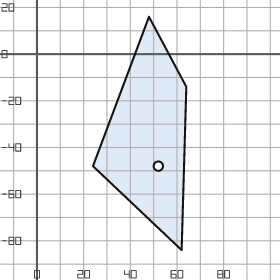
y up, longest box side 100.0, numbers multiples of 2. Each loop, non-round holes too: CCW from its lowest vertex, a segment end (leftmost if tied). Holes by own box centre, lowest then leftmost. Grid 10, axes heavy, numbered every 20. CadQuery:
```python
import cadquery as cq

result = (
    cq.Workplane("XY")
    .moveTo(62.0, -84.0)
    .lineTo(64.0, -14.0)
    .lineTo(48.0, 16.0)
    .lineTo(24.0, -48.0)
    .close()
    .moveTo(52.0, -48.0)
    .circle(2.0)
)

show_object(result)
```